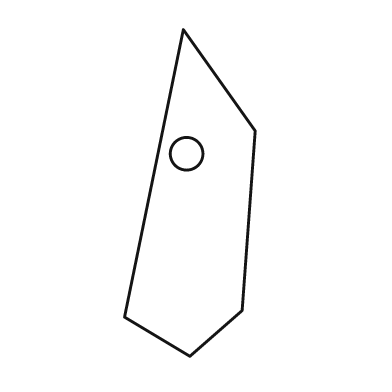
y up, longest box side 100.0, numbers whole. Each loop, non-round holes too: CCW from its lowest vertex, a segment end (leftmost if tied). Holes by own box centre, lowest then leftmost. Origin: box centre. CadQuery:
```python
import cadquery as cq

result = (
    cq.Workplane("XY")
    .moveTo(0.0, -50.0)
    .lineTo(16.0, -36.0)
    .lineTo(20.0, 19.0)
    .lineTo(-2.0, 50.0)
    .lineTo(-20.0, -38.0)
    .close()
    .moveTo(-1.0, 12.0)
    .circle(5.0)
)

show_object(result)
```